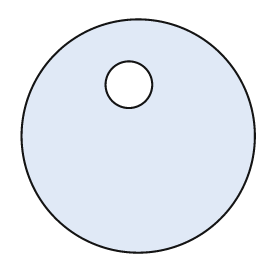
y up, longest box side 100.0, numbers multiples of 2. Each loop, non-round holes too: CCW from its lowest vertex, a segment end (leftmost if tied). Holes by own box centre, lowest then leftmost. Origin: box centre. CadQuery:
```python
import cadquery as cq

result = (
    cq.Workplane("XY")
    .moveTo(0.0, 0.0)
    .circle(50.0)
    .moveTo(-4.0, 22.0)
    .circle(10.0)
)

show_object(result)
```